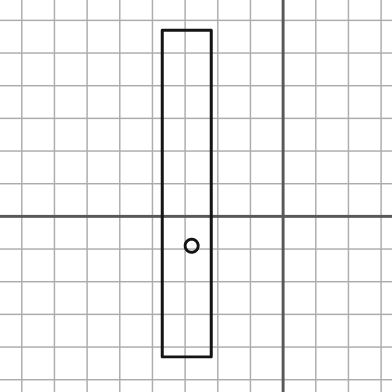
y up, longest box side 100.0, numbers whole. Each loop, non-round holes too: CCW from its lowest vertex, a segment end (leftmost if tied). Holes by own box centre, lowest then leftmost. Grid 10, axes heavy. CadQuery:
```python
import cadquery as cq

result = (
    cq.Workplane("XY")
    .moveTo(-37.0, -43.0)
    .lineTo(-22.0, -43.0)
    .lineTo(-22.0, 57.0)
    .lineTo(-37.0, 57.0)
    .close()
    .moveTo(-28.0, -9.0)
    .circle(2.0)
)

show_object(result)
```